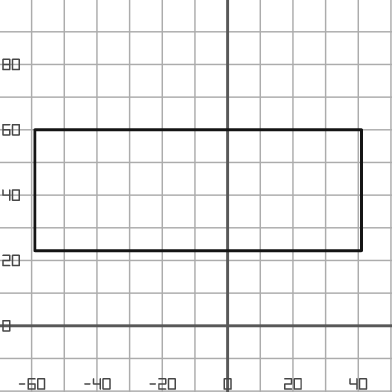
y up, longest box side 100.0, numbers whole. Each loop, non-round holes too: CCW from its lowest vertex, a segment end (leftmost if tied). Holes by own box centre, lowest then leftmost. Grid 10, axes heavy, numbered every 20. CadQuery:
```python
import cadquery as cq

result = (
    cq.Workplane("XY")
    .moveTo(-59.0, 23.0)
    .lineTo(41.0, 23.0)
    .lineTo(41.0, 60.0)
    .lineTo(-59.0, 60.0)
    .close()
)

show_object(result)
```